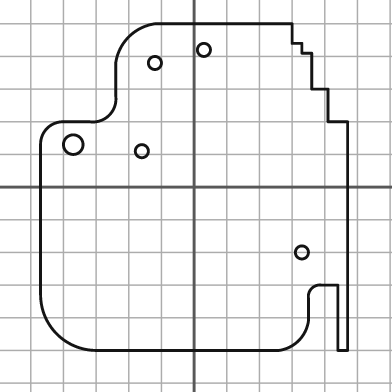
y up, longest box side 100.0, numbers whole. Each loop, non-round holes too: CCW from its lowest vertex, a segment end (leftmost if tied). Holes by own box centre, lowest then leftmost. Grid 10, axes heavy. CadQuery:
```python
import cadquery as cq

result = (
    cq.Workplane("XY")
    .moveTo(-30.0, -50.0)
    .lineTo(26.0, -50.0)
    .threePointArc((32.0, -47.0), (35.0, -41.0))
    .lineTo(35.0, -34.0)
    .threePointArc((36.0, -31.0), (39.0, -30.0))
    .lineTo(44.0, -30.0)
    .lineTo(44.0, -50.0)
    .lineTo(47.0, -50.0)
    .lineTo(47.0, 20.0)
    .lineTo(41.0, 20.0)
    .lineTo(41.0, 30.0)
    .lineTo(36.0, 30.0)
    .lineTo(36.0, 41.0)
    .lineTo(33.0, 41.0)
    .lineTo(33.0, 44.0)
    .lineTo(30.0, 44.0)
    .lineTo(30.0, 50.0)
    .lineTo(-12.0, 50.0)
    .threePointArc((-20.0, 46.0), (-24.0, 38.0))
    .lineTo(-24.0, 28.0)
    .threePointArc((-26.0, 22.0), (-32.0, 20.0))
    .lineTo(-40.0, 20.0)
    .threePointArc((-45.0, 18.0), (-47.0, 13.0))
    .lineTo(-47.0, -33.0)
    .threePointArc((-42.0, -45.0), (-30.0, -50.0))
    .close()
    .moveTo(33.0, -20.0)
    .circle(2.0)
    .moveTo(-16.0, 11.0)
    .circle(2.0)
    .moveTo(-37.0, 13.0)
    .circle(3.0)
    .moveTo(-12.0, 38.0)
    .circle(2.0)
    .moveTo(3.0, 42.0)
    .circle(2.0)
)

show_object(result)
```